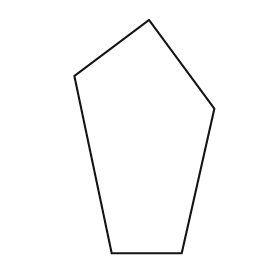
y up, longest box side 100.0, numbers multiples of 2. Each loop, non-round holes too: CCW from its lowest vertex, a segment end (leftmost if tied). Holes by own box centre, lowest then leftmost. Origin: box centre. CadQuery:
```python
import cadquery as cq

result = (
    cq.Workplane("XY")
    .moveTo(-14.0, -50.0)
    .lineTo(16.0, -50.0)
    .lineTo(30.0, 12.0)
    .lineTo(2.0, 50.0)
    .lineTo(-30.0, 26.0)
    .close()
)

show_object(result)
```